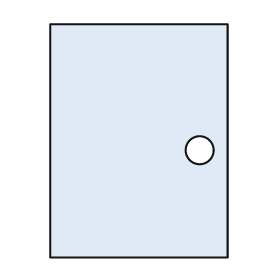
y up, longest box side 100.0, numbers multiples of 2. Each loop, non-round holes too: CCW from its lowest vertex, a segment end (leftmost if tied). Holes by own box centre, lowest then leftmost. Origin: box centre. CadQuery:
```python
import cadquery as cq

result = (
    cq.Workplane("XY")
    .moveTo(-38.0, -50.0)
    .lineTo(38.0, -50.0)
    .lineTo(38.0, 50.0)
    .lineTo(-38.0, 50.0)
    .close()
    .moveTo(26.0, -4.0)
    .circle(6.0)
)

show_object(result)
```